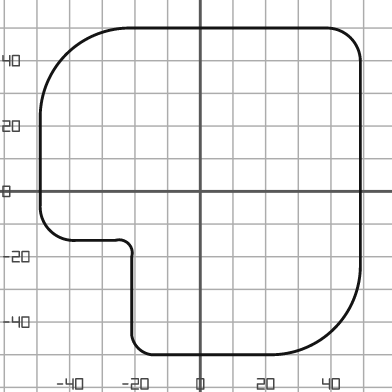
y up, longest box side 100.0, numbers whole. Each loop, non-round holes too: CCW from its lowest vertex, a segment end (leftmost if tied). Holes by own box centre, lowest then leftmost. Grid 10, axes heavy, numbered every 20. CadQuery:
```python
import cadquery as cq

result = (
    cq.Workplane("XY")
    .moveTo(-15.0, -50.0)
    .lineTo(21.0, -50.0)
    .threePointArc((41.0, -42.0), (49.0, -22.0))
    .lineTo(49.0, 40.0)
    .threePointArc((46.0, 47.0), (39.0, 50.0))
    .lineTo(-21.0, 50.0)
    .threePointArc((-41.0, 42.0), (-49.0, 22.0))
    .lineTo(-49.0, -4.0)
    .threePointArc((-46.0, -12.0), (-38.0, -15.0))
    .lineTo(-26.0, -15.0)
    .threePointArc((-22.0, -16.0), (-21.0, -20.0))
    .lineTo(-21.0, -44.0)
    .threePointArc((-19.0, -48.0), (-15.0, -50.0))
    .close()
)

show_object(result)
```